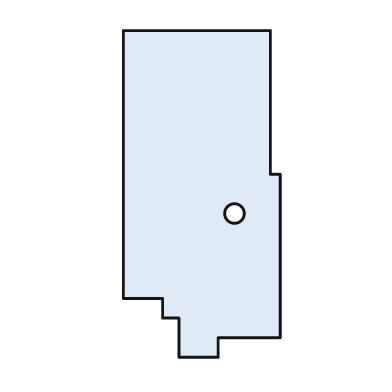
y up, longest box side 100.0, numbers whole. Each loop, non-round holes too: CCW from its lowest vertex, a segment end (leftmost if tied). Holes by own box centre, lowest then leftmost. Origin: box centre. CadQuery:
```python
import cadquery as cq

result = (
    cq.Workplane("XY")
    .moveTo(-7.0, -50.0)
    .lineTo(5.0, -50.0)
    .lineTo(5.0, -44.0)
    .lineTo(24.0, -44.0)
    .lineTo(24.0, 6.0)
    .lineTo(21.0, 6.0)
    .lineTo(21.0, 50.0)
    .lineTo(-24.0, 50.0)
    .lineTo(-24.0, -32.0)
    .lineTo(-12.0, -32.0)
    .lineTo(-12.0, -38.0)
    .lineTo(-7.0, -38.0)
    .close()
    .moveTo(10.0, -6.0)
    .circle(3.0)
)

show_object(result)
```